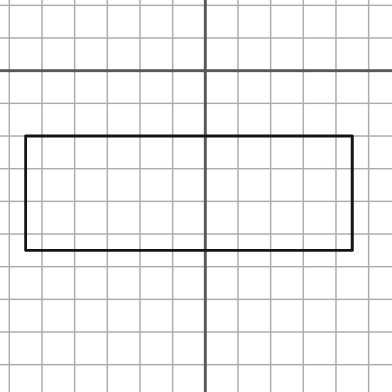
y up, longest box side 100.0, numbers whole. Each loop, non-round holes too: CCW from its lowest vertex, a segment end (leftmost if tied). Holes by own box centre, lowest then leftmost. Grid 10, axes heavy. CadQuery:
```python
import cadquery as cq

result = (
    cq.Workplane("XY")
    .moveTo(-55.0, -55.0)
    .lineTo(45.0, -55.0)
    .lineTo(45.0, -20.0)
    .lineTo(-55.0, -20.0)
    .close()
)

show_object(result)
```